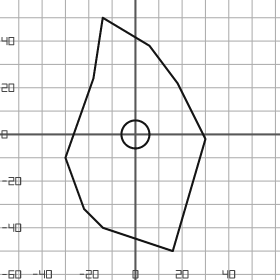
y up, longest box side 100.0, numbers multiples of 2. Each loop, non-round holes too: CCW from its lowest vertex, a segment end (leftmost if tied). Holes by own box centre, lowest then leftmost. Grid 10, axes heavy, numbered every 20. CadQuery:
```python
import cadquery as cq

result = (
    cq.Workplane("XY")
    .moveTo(16.0, -50.0)
    .lineTo(30.0, -2.0)
    .lineTo(18.0, 22.0)
    .lineTo(6.0, 38.0)
    .lineTo(-14.0, 50.0)
    .lineTo(-18.0, 24.0)
    .lineTo(-30.0, -10.0)
    .lineTo(-22.0, -32.0)
    .lineTo(-14.0, -40.0)
    .close()
    .moveTo(0.0, 0.0)
    .circle(6.0)
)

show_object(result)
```